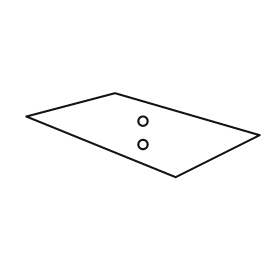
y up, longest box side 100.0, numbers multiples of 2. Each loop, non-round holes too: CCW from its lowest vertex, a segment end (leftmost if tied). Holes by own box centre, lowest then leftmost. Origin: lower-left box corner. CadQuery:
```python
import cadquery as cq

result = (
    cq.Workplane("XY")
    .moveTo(64.0, 0.0)
    .lineTo(100.0, 18.0)
    .lineTo(38.0, 36.0)
    .lineTo(0.0, 26.0)
    .close()
    .moveTo(50.0, 14.0)
    .circle(2.0)
    .moveTo(50.0, 24.0)
    .circle(2.0)
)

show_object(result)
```